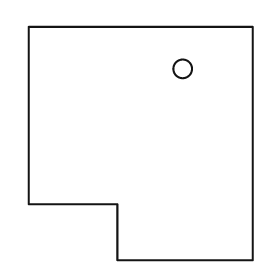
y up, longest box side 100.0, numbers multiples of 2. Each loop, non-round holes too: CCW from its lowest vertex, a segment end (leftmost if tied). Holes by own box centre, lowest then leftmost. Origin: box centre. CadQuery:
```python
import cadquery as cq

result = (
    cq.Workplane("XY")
    .moveTo(-10.0, -50.0)
    .lineTo(48.0, -50.0)
    .lineTo(48.0, 50.0)
    .lineTo(-48.0, 50.0)
    .lineTo(-48.0, -26.0)
    .lineTo(-10.0, -26.0)
    .close()
    .moveTo(18.0, 32.0)
    .circle(4.0)
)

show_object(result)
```